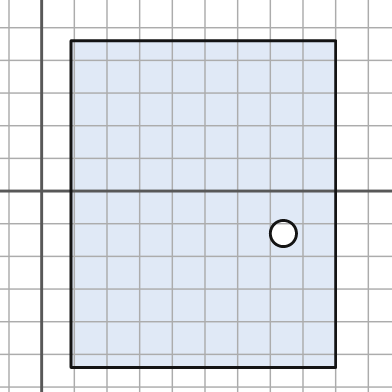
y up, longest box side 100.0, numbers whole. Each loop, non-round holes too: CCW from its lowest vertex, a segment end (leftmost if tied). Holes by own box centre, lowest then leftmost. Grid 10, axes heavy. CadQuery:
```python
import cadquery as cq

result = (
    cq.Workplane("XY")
    .moveTo(9.0, -54.0)
    .lineTo(90.0, -54.0)
    .lineTo(90.0, 46.0)
    .lineTo(9.0, 46.0)
    .close()
    .moveTo(74.0, -13.0)
    .circle(4.0)
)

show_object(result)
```